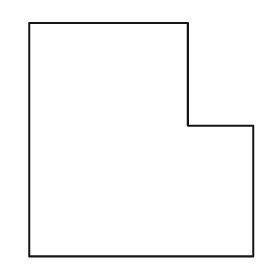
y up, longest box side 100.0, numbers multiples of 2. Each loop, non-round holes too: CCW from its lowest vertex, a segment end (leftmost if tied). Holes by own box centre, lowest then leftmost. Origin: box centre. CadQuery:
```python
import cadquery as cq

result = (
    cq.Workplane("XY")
    .moveTo(-48.0, -50.0)
    .lineTo(48.0, -50.0)
    .lineTo(48.0, 6.0)
    .lineTo(20.0, 6.0)
    .lineTo(20.0, 50.0)
    .lineTo(-48.0, 50.0)
    .close()
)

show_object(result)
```